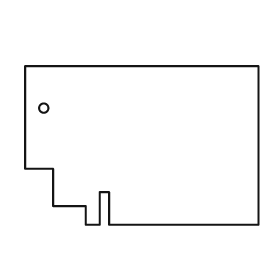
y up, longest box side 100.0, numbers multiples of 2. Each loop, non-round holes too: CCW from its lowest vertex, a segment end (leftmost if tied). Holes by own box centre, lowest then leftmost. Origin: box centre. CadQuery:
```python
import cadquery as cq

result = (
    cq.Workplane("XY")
    .moveTo(-24.0, -34.0)
    .lineTo(-18.0, -34.0)
    .lineTo(-18.0, -20.0)
    .lineTo(-14.0, -20.0)
    .lineTo(-14.0, -34.0)
    .lineTo(50.0, -34.0)
    .lineTo(50.0, 34.0)
    .lineTo(-50.0, 34.0)
    .lineTo(-50.0, -10.0)
    .lineTo(-38.0, -10.0)
    .lineTo(-38.0, -26.0)
    .lineTo(-24.0, -26.0)
    .close()
    .moveTo(-42.0, 16.0)
    .circle(2.0)
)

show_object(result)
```